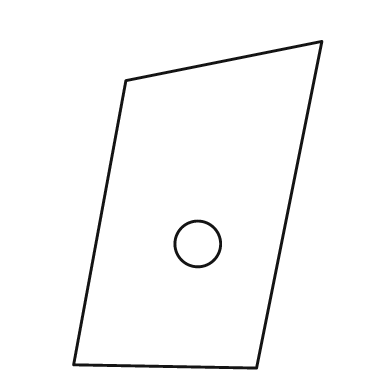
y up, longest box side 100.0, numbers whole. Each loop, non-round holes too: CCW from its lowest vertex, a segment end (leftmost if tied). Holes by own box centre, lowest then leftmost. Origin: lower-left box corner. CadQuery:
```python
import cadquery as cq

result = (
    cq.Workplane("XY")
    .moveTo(56.0, 0.0)
    .lineTo(76.0, 100.0)
    .lineTo(16.0, 88.0)
    .lineTo(0.0, 1.0)
    .close()
    .moveTo(38.0, 38.0)
    .circle(7.0)
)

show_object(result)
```